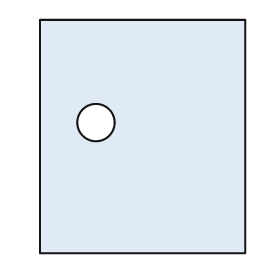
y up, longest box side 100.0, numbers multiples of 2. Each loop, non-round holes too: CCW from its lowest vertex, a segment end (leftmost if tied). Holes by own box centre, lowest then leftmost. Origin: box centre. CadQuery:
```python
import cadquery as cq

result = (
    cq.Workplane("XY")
    .moveTo(-44.0, -50.0)
    .lineTo(44.0, -50.0)
    .lineTo(44.0, 50.0)
    .lineTo(-44.0, 50.0)
    .close()
    .moveTo(-20.0, 6.0)
    .circle(8.0)
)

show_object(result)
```